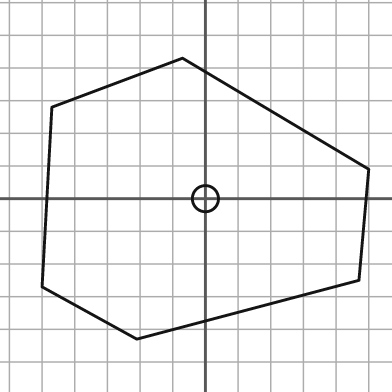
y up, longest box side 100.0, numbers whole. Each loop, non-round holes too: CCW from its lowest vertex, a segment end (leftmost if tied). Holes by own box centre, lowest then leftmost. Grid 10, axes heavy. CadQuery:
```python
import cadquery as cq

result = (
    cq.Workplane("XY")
    .moveTo(-21.0, -43.0)
    .lineTo(47.0, -25.0)
    .lineTo(50.0, 9.0)
    .lineTo(-7.0, 43.0)
    .lineTo(-47.0, 28.0)
    .lineTo(-50.0, -27.0)
    .close()
    .moveTo(0.0, 0.0)
    .circle(4.0)
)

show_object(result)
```